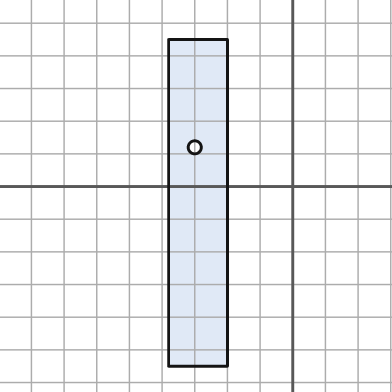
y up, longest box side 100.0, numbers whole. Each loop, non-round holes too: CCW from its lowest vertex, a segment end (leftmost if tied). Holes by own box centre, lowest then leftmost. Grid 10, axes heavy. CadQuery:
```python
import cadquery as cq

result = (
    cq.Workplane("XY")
    .moveTo(-38.0, -55.0)
    .lineTo(-20.0, -55.0)
    .lineTo(-20.0, 45.0)
    .lineTo(-38.0, 45.0)
    .close()
    .moveTo(-30.0, 12.0)
    .circle(2.0)
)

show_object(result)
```